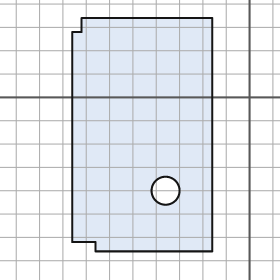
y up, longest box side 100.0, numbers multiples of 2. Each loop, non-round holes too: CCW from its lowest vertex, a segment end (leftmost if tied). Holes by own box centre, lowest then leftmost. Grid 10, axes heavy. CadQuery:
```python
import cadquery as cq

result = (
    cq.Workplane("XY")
    .moveTo(-66.0, -66.0)
    .lineTo(-16.0, -66.0)
    .lineTo(-16.0, 34.0)
    .lineTo(-72.0, 34.0)
    .lineTo(-72.0, 28.0)
    .lineTo(-76.0, 28.0)
    .lineTo(-76.0, -62.0)
    .lineTo(-66.0, -62.0)
    .close()
    .moveTo(-36.0, -40.0)
    .circle(6.0)
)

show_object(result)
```